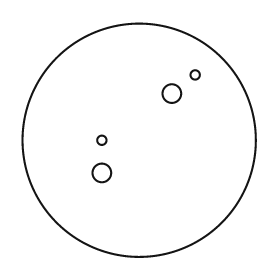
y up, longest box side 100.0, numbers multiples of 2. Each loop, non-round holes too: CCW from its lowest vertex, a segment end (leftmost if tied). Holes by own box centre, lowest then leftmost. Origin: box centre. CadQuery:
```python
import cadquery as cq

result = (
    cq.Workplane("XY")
    .moveTo(0.0, 0.0)
    .circle(50.0)
    .moveTo(-16.0, -14.0)
    .circle(4.0)
    .moveTo(-16.0, 0.0)
    .circle(2.0)
    .moveTo(14.0, 20.0)
    .circle(4.0)
    .moveTo(24.0, 28.0)
    .circle(2.0)
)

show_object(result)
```